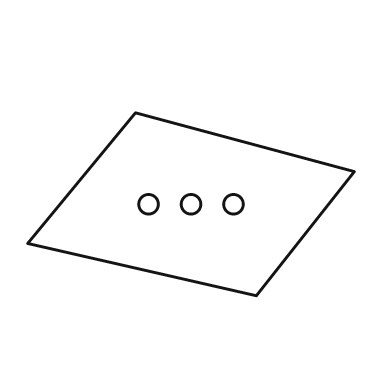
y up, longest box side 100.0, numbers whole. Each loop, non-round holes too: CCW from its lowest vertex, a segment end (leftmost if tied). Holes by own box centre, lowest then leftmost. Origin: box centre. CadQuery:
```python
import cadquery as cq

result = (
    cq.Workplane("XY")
    .moveTo(20.0, -28.0)
    .lineTo(50.0, 10.0)
    .lineTo(-17.0, 28.0)
    .lineTo(-50.0, -12.0)
    .close()
    .moveTo(-13.0, 0.0)
    .circle(3.0)
    .moveTo(0.0, 0.0)
    .circle(3.0)
    .moveTo(13.0, 0.0)
    .circle(3.0)
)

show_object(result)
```